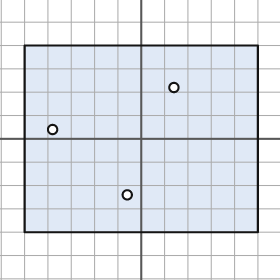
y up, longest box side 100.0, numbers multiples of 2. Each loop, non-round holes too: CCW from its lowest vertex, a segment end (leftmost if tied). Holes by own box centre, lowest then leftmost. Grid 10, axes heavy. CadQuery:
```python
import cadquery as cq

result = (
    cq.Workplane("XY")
    .moveTo(-50.0, -40.0)
    .lineTo(50.0, -40.0)
    .lineTo(50.0, 40.0)
    .lineTo(-50.0, 40.0)
    .close()
    .moveTo(-6.0, -24.0)
    .circle(2.0)
    .moveTo(-38.0, 4.0)
    .circle(2.0)
    .moveTo(14.0, 22.0)
    .circle(2.0)
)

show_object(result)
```